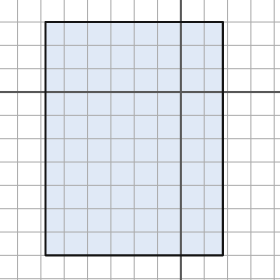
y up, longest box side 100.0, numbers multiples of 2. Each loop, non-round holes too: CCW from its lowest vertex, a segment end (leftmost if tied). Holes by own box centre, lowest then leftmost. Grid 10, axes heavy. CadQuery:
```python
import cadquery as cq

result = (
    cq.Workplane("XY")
    .moveTo(-58.0, -70.0)
    .lineTo(18.0, -70.0)
    .lineTo(18.0, 30.0)
    .lineTo(-58.0, 30.0)
    .close()
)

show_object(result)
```